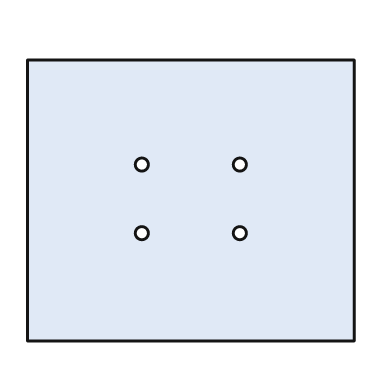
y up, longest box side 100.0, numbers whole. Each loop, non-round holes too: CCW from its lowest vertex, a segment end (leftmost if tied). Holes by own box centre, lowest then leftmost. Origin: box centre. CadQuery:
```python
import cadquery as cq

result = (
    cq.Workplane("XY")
    .moveTo(-50.0, -43.0)
    .lineTo(50.0, -43.0)
    .lineTo(50.0, 43.0)
    .lineTo(-50.0, 43.0)
    .close()
    .moveTo(-15.0, -10.0)
    .circle(2.0)
    .moveTo(15.0, -10.0)
    .circle(2.0)
    .moveTo(-15.0, 11.0)
    .circle(2.0)
    .moveTo(15.0, 11.0)
    .circle(2.0)
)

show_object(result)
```